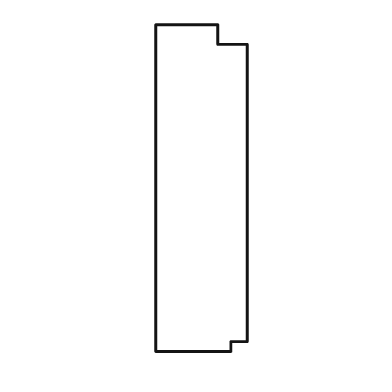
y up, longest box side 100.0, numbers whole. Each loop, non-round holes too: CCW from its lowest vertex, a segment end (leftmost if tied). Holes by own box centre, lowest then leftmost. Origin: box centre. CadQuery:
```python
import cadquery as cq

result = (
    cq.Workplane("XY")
    .moveTo(-14.0, -50.0)
    .lineTo(9.0, -50.0)
    .lineTo(9.0, -47.0)
    .lineTo(14.0, -47.0)
    .lineTo(14.0, 44.0)
    .lineTo(5.0, 44.0)
    .lineTo(5.0, 50.0)
    .lineTo(-14.0, 50.0)
    .close()
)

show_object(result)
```